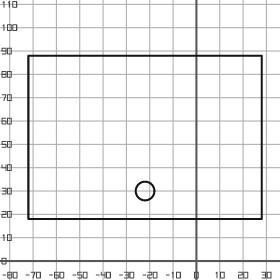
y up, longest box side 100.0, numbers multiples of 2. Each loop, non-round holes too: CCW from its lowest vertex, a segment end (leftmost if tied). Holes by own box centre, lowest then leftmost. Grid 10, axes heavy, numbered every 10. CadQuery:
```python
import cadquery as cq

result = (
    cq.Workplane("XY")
    .moveTo(-72.0, 18.0)
    .lineTo(28.0, 18.0)
    .lineTo(28.0, 88.0)
    .lineTo(-72.0, 88.0)
    .close()
    .moveTo(-22.0, 30.0)
    .circle(4.0)
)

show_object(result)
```